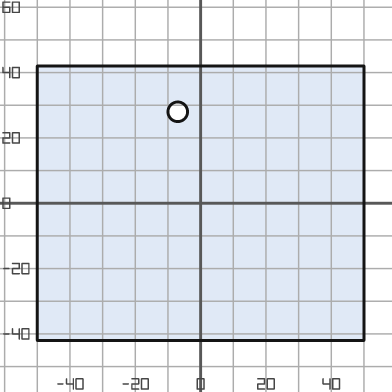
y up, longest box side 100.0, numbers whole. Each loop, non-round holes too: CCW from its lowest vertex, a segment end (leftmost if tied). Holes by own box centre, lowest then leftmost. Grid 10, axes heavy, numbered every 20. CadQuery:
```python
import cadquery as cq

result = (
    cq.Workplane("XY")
    .moveTo(-50.0, -42.0)
    .lineTo(50.0, -42.0)
    .lineTo(50.0, 42.0)
    .lineTo(-50.0, 42.0)
    .close()
    .moveTo(-7.0, 28.0)
    .circle(3.0)
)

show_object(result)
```